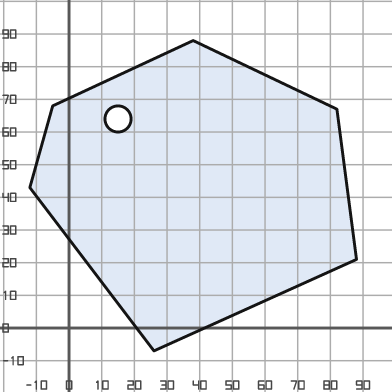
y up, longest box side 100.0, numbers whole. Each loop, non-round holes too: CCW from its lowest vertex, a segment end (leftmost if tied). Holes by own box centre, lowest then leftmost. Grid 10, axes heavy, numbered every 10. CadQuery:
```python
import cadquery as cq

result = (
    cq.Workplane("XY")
    .moveTo(26.0, -7.0)
    .lineTo(88.0, 21.0)
    .lineTo(82.0, 67.0)
    .lineTo(38.0, 88.0)
    .lineTo(-5.0, 68.0)
    .lineTo(-12.0, 43.0)
    .close()
    .moveTo(15.0, 64.0)
    .circle(4.0)
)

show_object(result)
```